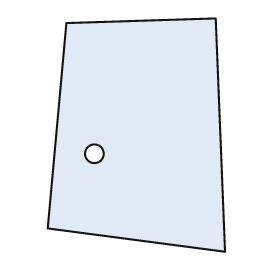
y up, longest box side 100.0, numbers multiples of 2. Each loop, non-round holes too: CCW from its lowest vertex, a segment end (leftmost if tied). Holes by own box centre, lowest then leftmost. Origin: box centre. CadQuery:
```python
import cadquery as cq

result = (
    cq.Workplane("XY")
    .moveTo(38.0, -50.0)
    .lineTo(34.0, 50.0)
    .lineTo(-30.0, 48.0)
    .lineTo(-38.0, -40.0)
    .close()
    .moveTo(-18.0, -8.0)
    .circle(4.0)
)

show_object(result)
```